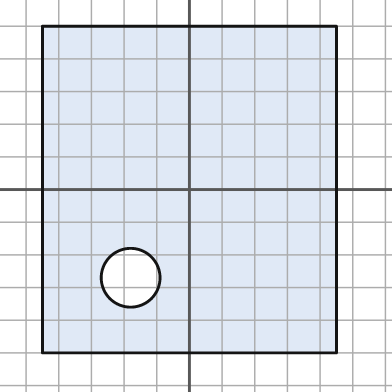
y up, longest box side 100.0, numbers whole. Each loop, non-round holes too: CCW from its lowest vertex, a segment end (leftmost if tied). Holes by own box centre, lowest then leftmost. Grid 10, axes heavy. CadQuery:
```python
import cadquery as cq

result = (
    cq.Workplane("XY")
    .moveTo(-45.0, -50.0)
    .lineTo(45.0, -50.0)
    .lineTo(45.0, 50.0)
    .lineTo(-45.0, 50.0)
    .close()
    .moveTo(-18.0, -27.0)
    .circle(9.0)
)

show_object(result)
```